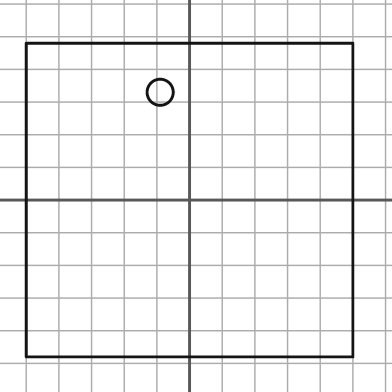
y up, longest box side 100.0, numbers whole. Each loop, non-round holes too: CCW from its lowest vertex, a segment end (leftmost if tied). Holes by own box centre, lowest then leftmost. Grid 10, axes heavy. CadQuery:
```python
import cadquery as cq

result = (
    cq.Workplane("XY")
    .moveTo(-50.0, -48.0)
    .lineTo(50.0, -48.0)
    .lineTo(50.0, 48.0)
    .lineTo(-50.0, 48.0)
    .close()
    .moveTo(-9.0, 33.0)
    .circle(4.0)
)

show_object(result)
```